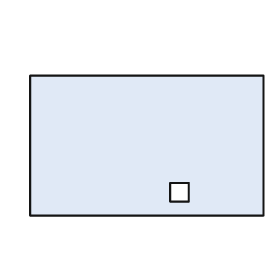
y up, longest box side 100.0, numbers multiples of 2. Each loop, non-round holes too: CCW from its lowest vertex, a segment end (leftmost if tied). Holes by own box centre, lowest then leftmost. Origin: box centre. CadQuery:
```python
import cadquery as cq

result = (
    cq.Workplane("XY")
    .moveTo(-50.0, -30.0)
    .lineTo(50.0, -30.0)
    .lineTo(50.0, 30.0)
    .lineTo(-50.0, 30.0)
    .close()
    .moveTo(10.0, -24.0)
    .lineTo(18.0, -24.0)
    .lineTo(18.0, -16.0)
    .lineTo(10.0, -16.0)
    .close()
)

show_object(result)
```